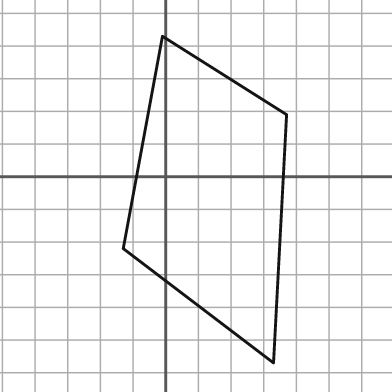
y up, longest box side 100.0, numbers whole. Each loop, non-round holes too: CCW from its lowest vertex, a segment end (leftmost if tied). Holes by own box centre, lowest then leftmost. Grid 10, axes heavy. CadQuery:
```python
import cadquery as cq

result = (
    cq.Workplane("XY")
    .moveTo(33.0, -57.0)
    .lineTo(37.0, 19.0)
    .lineTo(-1.0, 43.0)
    .lineTo(-13.0, -22.0)
    .close()
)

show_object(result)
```